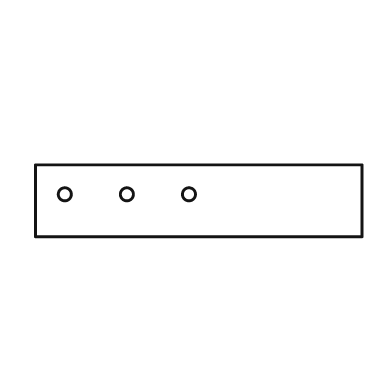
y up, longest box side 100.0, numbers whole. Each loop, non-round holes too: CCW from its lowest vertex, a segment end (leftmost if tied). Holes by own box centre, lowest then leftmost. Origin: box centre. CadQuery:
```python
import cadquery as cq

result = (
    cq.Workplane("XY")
    .moveTo(-50.0, -11.0)
    .lineTo(50.0, -11.0)
    .lineTo(50.0, 11.0)
    .lineTo(-50.0, 11.0)
    .close()
    .moveTo(-41.0, 2.0)
    .circle(2.0)
    .moveTo(-22.0, 2.0)
    .circle(2.0)
    .moveTo(-3.0, 2.0)
    .circle(2.0)
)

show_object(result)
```